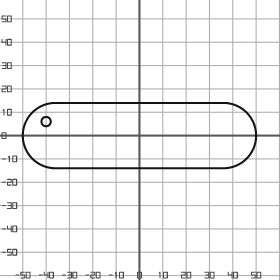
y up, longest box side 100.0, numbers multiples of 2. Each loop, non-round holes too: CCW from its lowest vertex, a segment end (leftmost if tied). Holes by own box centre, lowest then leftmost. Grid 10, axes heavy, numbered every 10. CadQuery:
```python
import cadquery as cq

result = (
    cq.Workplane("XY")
    .moveTo(-36.0, -14.0)
    .lineTo(36.0, -14.0)
    .threePointArc((50.0, 0.0), (36.0, 14.0))
    .lineTo(-36.0, 14.0)
    .threePointArc((-50.0, 0.0), (-36.0, -14.0))
    .close()
    .moveTo(-40.0, 6.0)
    .circle(2.0)
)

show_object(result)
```